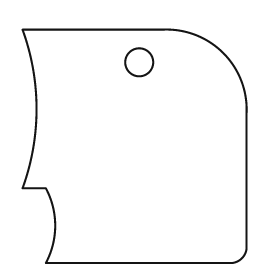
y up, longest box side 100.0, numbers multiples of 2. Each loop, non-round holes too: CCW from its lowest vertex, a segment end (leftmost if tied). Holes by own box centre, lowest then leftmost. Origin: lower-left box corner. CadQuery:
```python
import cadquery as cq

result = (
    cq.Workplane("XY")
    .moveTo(10.0, 0.0)
    .lineTo(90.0, 0.0)
    .threePointArc((94.0, 2.0), (96.0, 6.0))
    .lineTo(96.0, 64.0)
    .threePointArc((86.0, 90.0), (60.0, 100.0))
    .lineTo(0.0, 100.0)
    .threePointArc((6.0, 66.0), (0.0, 32.0))
    .lineTo(10.0, 32.0)
    .threePointArc((14.0, 16.0), (10.0, 0.0))
    .close()
    .moveTo(50.0, 86.0)
    .circle(6.0)
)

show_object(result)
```